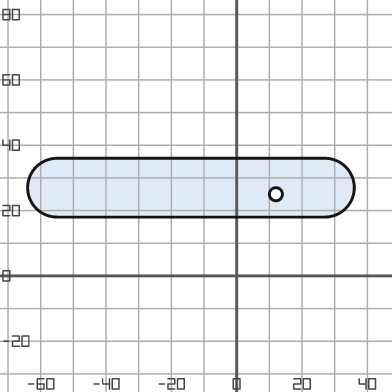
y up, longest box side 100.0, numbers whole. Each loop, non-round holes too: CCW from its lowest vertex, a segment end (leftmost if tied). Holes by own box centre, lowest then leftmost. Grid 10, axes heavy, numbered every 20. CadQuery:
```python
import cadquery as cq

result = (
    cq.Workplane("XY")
    .moveTo(-55.0, 18.0)
    .lineTo(27.0, 18.0)
    .threePointArc((36.0, 27.0), (27.0, 36.0))
    .lineTo(-55.0, 36.0)
    .threePointArc((-64.0, 27.0), (-55.0, 18.0))
    .close()
    .moveTo(12.0, 25.0)
    .circle(2.0)
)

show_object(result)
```